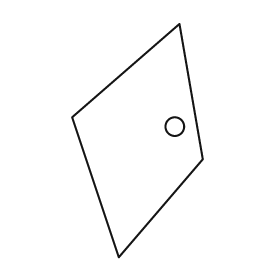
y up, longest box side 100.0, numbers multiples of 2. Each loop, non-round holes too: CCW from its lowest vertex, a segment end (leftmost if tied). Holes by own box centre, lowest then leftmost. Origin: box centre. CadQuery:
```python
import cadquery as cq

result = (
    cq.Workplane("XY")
    .moveTo(-8.0, -50.0)
    .lineTo(28.0, -8.0)
    .lineTo(18.0, 50.0)
    .lineTo(-28.0, 10.0)
    .close()
    .moveTo(16.0, 6.0)
    .circle(4.0)
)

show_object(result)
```